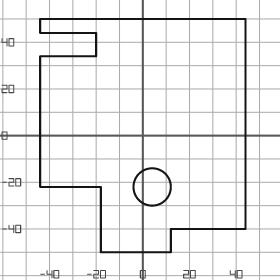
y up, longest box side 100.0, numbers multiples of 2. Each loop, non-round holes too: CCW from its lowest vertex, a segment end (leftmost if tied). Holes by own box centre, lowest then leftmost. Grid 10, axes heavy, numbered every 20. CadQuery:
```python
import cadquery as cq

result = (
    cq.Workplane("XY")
    .moveTo(-18.0, -50.0)
    .lineTo(12.0, -50.0)
    .lineTo(12.0, -40.0)
    .lineTo(44.0, -40.0)
    .lineTo(44.0, 50.0)
    .lineTo(-44.0, 50.0)
    .lineTo(-44.0, 44.0)
    .lineTo(-20.0, 44.0)
    .lineTo(-20.0, 34.0)
    .lineTo(-44.0, 34.0)
    .lineTo(-44.0, -22.0)
    .lineTo(-18.0, -22.0)
    .close()
    .moveTo(4.0, -22.0)
    .circle(8.0)
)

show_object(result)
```